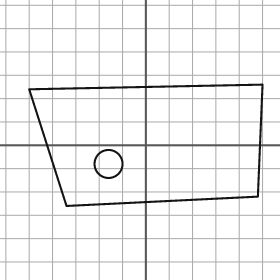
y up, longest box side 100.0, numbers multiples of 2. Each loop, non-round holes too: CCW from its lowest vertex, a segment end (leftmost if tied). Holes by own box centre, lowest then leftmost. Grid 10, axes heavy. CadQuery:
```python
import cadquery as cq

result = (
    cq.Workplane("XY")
    .moveTo(-34.0, -26.0)
    .lineTo(48.0, -22.0)
    .lineTo(50.0, 26.0)
    .lineTo(-50.0, 24.0)
    .close()
    .moveTo(-16.0, -8.0)
    .circle(6.0)
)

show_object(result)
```